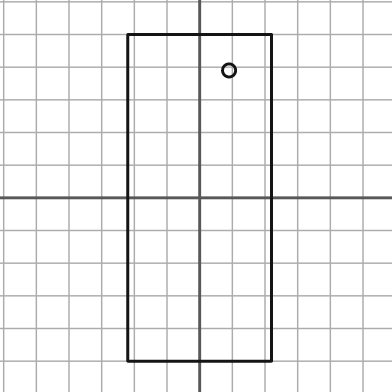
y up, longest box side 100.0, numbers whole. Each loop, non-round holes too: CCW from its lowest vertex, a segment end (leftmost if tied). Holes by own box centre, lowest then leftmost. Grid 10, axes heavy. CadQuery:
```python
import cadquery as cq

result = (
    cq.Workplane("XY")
    .moveTo(-22.0, -50.0)
    .lineTo(22.0, -50.0)
    .lineTo(22.0, 50.0)
    .lineTo(-22.0, 50.0)
    .close()
    .moveTo(9.0, 39.0)
    .circle(2.0)
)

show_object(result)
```